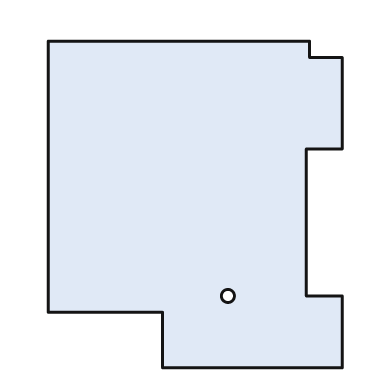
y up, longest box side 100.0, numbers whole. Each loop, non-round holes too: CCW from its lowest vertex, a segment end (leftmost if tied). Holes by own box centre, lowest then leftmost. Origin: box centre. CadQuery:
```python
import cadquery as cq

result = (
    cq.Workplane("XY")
    .moveTo(-10.0, -50.0)
    .lineTo(45.0, -50.0)
    .lineTo(45.0, -28.0)
    .lineTo(34.0, -28.0)
    .lineTo(34.0, 17.0)
    .lineTo(45.0, 17.0)
    .lineTo(45.0, 45.0)
    .lineTo(35.0, 45.0)
    .lineTo(35.0, 50.0)
    .lineTo(-45.0, 50.0)
    .lineTo(-45.0, -33.0)
    .lineTo(-10.0, -33.0)
    .close()
    .moveTo(10.0, -28.0)
    .circle(2.0)
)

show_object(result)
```